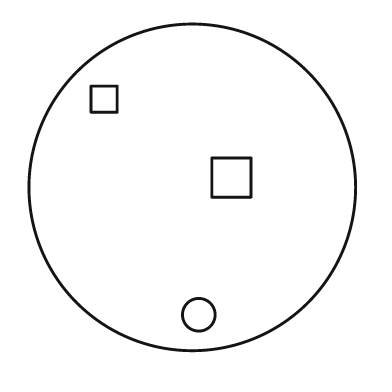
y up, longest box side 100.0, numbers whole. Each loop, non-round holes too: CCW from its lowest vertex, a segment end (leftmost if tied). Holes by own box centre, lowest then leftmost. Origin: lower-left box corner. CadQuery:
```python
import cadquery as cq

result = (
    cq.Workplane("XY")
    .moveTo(50.0, 50.0)
    .circle(50.0)
    .moveTo(52.0, 11.0)
    .circle(5.0)
    .moveTo(56.0, 47.0)
    .lineTo(68.0, 47.0)
    .lineTo(68.0, 59.0)
    .lineTo(56.0, 59.0)
    .close()
    .moveTo(19.0, 73.0)
    .lineTo(27.0, 73.0)
    .lineTo(27.0, 81.0)
    .lineTo(19.0, 81.0)
    .close()
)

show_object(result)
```